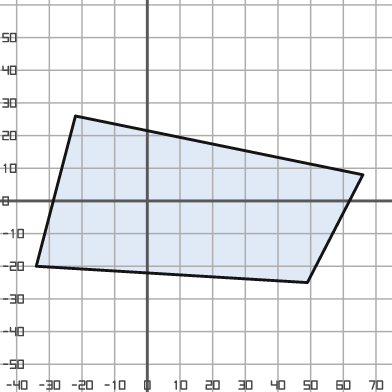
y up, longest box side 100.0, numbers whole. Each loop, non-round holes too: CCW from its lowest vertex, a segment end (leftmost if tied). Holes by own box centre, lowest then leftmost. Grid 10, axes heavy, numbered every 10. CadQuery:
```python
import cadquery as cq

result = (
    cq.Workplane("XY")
    .moveTo(49.0, -25.0)
    .lineTo(66.0, 8.0)
    .lineTo(-22.0, 26.0)
    .lineTo(-34.0, -20.0)
    .close()
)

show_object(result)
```